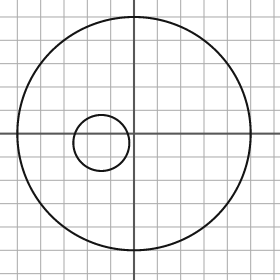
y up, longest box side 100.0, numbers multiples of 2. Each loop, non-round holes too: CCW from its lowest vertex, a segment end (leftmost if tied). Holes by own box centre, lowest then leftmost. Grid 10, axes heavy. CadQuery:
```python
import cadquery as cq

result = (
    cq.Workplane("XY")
    .moveTo(0.0, 0.0)
    .circle(50.0)
    .moveTo(-14.0, -4.0)
    .circle(12.0)
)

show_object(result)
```